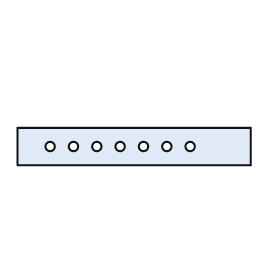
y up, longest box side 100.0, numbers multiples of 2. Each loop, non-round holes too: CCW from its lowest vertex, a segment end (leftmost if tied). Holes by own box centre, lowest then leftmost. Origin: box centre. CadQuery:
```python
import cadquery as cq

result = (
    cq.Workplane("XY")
    .moveTo(-50.0, -8.0)
    .lineTo(50.0, -8.0)
    .lineTo(50.0, 8.0)
    .lineTo(-50.0, 8.0)
    .close()
    .moveTo(-36.0, 0.0)
    .circle(2.0)
    .moveTo(-26.0, 0.0)
    .circle(2.0)
    .moveTo(-16.0, 0.0)
    .circle(2.0)
    .moveTo(-6.0, 0.0)
    .circle(2.0)
    .moveTo(4.0, 0.0)
    .circle(2.0)
    .moveTo(14.0, 0.0)
    .circle(2.0)
    .moveTo(24.0, 0.0)
    .circle(2.0)
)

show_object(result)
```